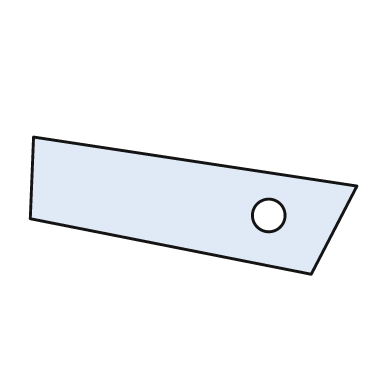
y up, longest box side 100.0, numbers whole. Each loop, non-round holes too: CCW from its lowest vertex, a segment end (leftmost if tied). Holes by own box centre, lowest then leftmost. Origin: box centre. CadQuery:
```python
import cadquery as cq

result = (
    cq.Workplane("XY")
    .moveTo(36.0, -21.0)
    .lineTo(50.0, 6.0)
    .lineTo(-49.0, 21.0)
    .lineTo(-50.0, -4.0)
    .close()
    .moveTo(23.0, -3.0)
    .circle(5.0)
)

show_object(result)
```